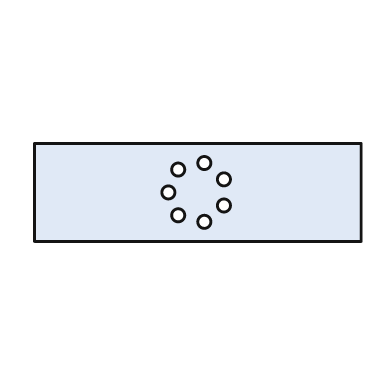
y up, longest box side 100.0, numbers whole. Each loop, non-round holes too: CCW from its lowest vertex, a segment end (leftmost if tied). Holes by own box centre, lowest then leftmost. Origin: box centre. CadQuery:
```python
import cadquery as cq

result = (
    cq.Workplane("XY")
    .moveTo(-50.0, -15.0)
    .lineTo(50.0, -15.0)
    .lineTo(50.0, 15.0)
    .lineTo(-50.0, 15.0)
    .close()
    .moveTo(2.0, -9.0)
    .circle(2.0)
    .moveTo(-6.0, -7.0)
    .circle(2.0)
    .moveTo(8.0, -4.0)
    .circle(2.0)
    .moveTo(-9.0, 0.0)
    .circle(2.0)
    .moveTo(8.0, 4.0)
    .circle(2.0)
    .moveTo(-6.0, 7.0)
    .circle(2.0)
    .moveTo(2.0, 9.0)
    .circle(2.0)
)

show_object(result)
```